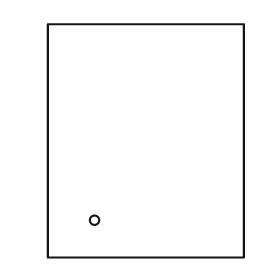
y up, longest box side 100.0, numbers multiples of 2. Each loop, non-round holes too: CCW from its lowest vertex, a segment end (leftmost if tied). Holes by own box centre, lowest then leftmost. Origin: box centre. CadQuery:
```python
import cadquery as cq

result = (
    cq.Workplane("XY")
    .moveTo(-42.0, -50.0)
    .lineTo(42.0, -50.0)
    .lineTo(42.0, 50.0)
    .lineTo(-42.0, 50.0)
    .close()
    .moveTo(-22.0, -34.0)
    .circle(2.0)
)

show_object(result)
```